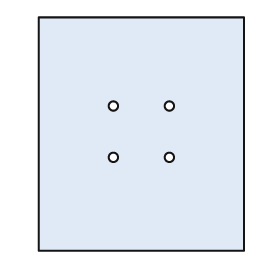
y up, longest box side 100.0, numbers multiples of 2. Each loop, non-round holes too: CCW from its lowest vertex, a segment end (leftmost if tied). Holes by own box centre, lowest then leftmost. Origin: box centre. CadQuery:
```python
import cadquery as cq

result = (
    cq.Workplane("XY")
    .moveTo(-44.0, -50.0)
    .lineTo(44.0, -50.0)
    .lineTo(44.0, 50.0)
    .lineTo(-44.0, 50.0)
    .close()
    .moveTo(-12.0, -10.0)
    .circle(2.0)
    .moveTo(12.0, -10.0)
    .circle(2.0)
    .moveTo(-12.0, 12.0)
    .circle(2.0)
    .moveTo(12.0, 12.0)
    .circle(2.0)
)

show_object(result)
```